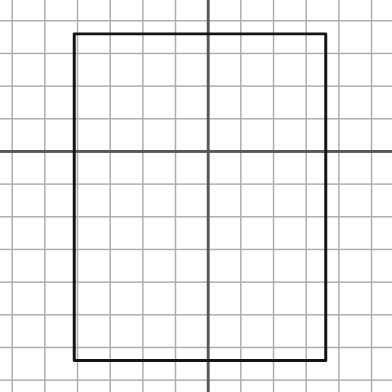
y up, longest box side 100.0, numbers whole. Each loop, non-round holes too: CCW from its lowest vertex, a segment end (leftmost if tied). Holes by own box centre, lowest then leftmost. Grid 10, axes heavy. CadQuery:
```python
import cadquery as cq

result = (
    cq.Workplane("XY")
    .moveTo(-41.0, -64.0)
    .lineTo(36.0, -64.0)
    .lineTo(36.0, 36.0)
    .lineTo(-41.0, 36.0)
    .close()
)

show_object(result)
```